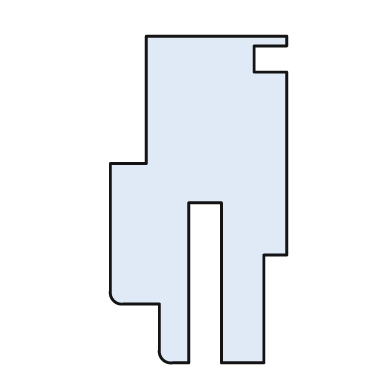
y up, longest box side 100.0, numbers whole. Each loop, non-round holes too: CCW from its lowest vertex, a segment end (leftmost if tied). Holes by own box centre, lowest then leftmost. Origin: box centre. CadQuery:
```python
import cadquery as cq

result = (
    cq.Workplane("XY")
    .moveTo(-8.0, -50.0)
    .lineTo(-3.0, -50.0)
    .lineTo(-3.0, -1.0)
    .lineTo(7.0, -1.0)
    .lineTo(7.0, -50.0)
    .lineTo(20.0, -50.0)
    .lineTo(20.0, -17.0)
    .lineTo(27.0, -17.0)
    .lineTo(27.0, 39.0)
    .lineTo(17.0, 39.0)
    .lineTo(17.0, 47.0)
    .lineTo(27.0, 47.0)
    .lineTo(27.0, 50.0)
    .lineTo(-16.0, 50.0)
    .lineTo(-16.0, 11.0)
    .lineTo(-27.0, 11.0)
    .lineTo(-27.0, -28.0)
    .threePointArc((-26.0, -31.0), (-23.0, -32.0))
    .lineTo(-12.0, -32.0)
    .lineTo(-12.0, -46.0)
    .threePointArc((-11.0, -49.0), (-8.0, -50.0))
    .close()
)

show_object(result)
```